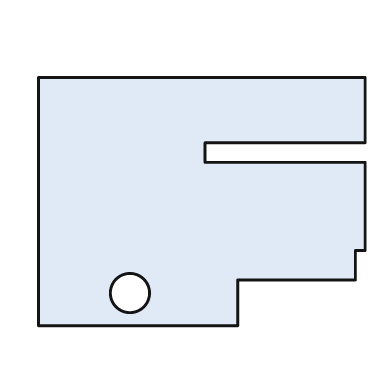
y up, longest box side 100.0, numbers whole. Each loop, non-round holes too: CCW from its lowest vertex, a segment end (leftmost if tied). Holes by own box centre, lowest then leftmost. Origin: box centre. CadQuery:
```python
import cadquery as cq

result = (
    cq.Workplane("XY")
    .moveTo(-50.0, -38.0)
    .lineTo(11.0, -38.0)
    .lineTo(11.0, -24.0)
    .lineTo(47.0, -24.0)
    .lineTo(47.0, -15.0)
    .lineTo(50.0, -15.0)
    .lineTo(50.0, 12.0)
    .lineTo(1.0, 12.0)
    .lineTo(1.0, 18.0)
    .lineTo(50.0, 18.0)
    .lineTo(50.0, 38.0)
    .lineTo(-50.0, 38.0)
    .close()
    .moveTo(-22.0, -28.0)
    .circle(6.0)
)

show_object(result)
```